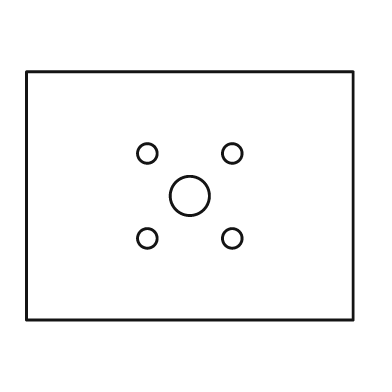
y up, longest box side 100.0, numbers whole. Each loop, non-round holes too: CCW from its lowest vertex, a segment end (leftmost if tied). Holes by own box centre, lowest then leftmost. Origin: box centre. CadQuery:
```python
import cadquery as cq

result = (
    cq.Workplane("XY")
    .moveTo(-50.0, -38.0)
    .lineTo(50.0, -38.0)
    .lineTo(50.0, 38.0)
    .lineTo(-50.0, 38.0)
    .close()
    .moveTo(-13.0, -13.0)
    .circle(3.0)
    .moveTo(13.0, -13.0)
    .circle(3.0)
    .moveTo(0.0, 0.0)
    .circle(6.0)
    .moveTo(-13.0, 13.0)
    .circle(3.0)
    .moveTo(13.0, 13.0)
    .circle(3.0)
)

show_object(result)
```